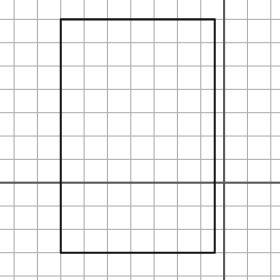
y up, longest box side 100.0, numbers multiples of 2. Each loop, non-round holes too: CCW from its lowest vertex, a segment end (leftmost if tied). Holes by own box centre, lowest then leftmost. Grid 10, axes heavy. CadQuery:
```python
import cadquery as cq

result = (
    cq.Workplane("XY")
    .moveTo(-70.0, -30.0)
    .lineTo(-4.0, -30.0)
    .lineTo(-4.0, 70.0)
    .lineTo(-70.0, 70.0)
    .close()
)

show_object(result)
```